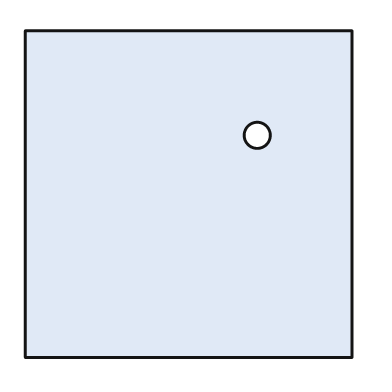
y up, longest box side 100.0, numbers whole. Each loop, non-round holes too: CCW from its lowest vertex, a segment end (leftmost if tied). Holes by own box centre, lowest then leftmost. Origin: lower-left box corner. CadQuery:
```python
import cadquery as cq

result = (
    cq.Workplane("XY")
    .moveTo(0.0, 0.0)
    .lineTo(100.0, 0.0)
    .lineTo(100.0, 100.0)
    .lineTo(0.0, 100.0)
    .close()
    .moveTo(71.0, 68.0)
    .circle(4.0)
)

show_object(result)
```